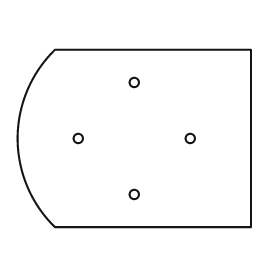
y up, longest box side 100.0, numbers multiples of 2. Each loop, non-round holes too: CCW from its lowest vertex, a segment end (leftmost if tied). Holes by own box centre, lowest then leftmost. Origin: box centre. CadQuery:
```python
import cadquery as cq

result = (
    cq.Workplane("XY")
    .moveTo(-34.0, -38.0)
    .lineTo(50.0, -38.0)
    .lineTo(50.0, 38.0)
    .lineTo(-34.0, 38.0)
    .threePointArc((-50.0, 0.0), (-34.0, -38.0))
    .close()
    .moveTo(0.0, -24.0)
    .circle(2.0)
    .moveTo(-24.0, 0.0)
    .circle(2.0)
    .moveTo(24.0, 0.0)
    .circle(2.0)
    .moveTo(0.0, 24.0)
    .circle(2.0)
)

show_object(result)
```